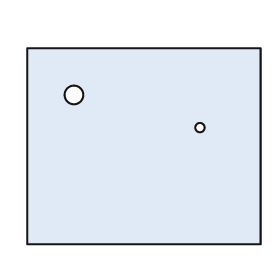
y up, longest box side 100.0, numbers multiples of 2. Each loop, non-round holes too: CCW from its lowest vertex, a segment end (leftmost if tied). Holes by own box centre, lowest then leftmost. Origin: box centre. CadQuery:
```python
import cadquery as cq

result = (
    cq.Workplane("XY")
    .moveTo(-50.0, -42.0)
    .lineTo(50.0, -42.0)
    .lineTo(50.0, 42.0)
    .lineTo(-50.0, 42.0)
    .close()
    .moveTo(24.0, 8.0)
    .circle(2.0)
    .moveTo(-30.0, 22.0)
    .circle(4.0)
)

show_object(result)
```